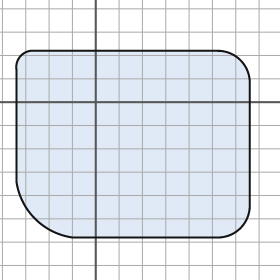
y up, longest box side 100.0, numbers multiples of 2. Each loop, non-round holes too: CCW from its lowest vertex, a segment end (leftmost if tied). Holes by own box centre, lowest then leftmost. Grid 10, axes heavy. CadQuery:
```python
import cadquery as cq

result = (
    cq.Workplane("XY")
    .moveTo(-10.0, -58.0)
    .lineTo(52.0, -58.0)
    .threePointArc((62.0, -54.0), (66.0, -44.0))
    .lineTo(66.0, 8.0)
    .threePointArc((62.0, 18.0), (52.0, 22.0))
    .lineTo(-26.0, 22.0)
    .threePointArc((-32.0, 20.0), (-34.0, 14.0))
    .lineTo(-34.0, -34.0)
    .threePointArc((-26.0, -50.0), (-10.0, -58.0))
    .close()
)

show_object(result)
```